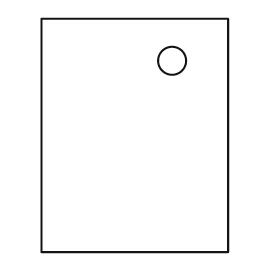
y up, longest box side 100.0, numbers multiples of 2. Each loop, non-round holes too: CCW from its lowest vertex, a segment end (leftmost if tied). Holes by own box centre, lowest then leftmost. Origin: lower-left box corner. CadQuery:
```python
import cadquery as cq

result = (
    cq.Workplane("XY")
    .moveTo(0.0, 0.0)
    .lineTo(80.0, 0.0)
    .lineTo(80.0, 100.0)
    .lineTo(0.0, 100.0)
    .close()
    .moveTo(56.0, 82.0)
    .circle(6.0)
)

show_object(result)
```